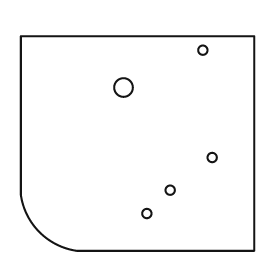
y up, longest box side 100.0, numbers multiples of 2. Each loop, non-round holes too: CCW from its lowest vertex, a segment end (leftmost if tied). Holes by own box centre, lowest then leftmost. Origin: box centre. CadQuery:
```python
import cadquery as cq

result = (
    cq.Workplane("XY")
    .moveTo(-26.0, -46.0)
    .lineTo(50.0, -46.0)
    .lineTo(50.0, 46.0)
    .lineTo(-50.0, 46.0)
    .lineTo(-50.0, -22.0)
    .threePointArc((-42.0, -38.0), (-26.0, -46.0))
    .close()
    .moveTo(4.0, -30.0)
    .circle(2.0)
    .moveTo(14.0, -20.0)
    .circle(2.0)
    .moveTo(32.0, -6.0)
    .circle(2.0)
    .moveTo(-6.0, 24.0)
    .circle(4.0)
    .moveTo(28.0, 40.0)
    .circle(2.0)
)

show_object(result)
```